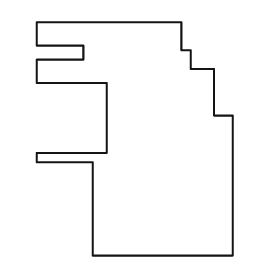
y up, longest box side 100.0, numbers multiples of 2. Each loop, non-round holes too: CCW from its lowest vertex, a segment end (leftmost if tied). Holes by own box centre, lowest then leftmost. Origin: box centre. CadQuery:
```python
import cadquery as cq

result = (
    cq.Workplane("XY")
    .moveTo(-18.0, -50.0)
    .lineTo(42.0, -50.0)
    .lineTo(42.0, 10.0)
    .lineTo(34.0, 10.0)
    .lineTo(34.0, 30.0)
    .lineTo(24.0, 30.0)
    .lineTo(24.0, 38.0)
    .lineTo(20.0, 38.0)
    .lineTo(20.0, 50.0)
    .lineTo(-42.0, 50.0)
    .lineTo(-42.0, 40.0)
    .lineTo(-22.0, 40.0)
    .lineTo(-22.0, 34.0)
    .lineTo(-42.0, 34.0)
    .lineTo(-42.0, 24.0)
    .lineTo(-12.0, 24.0)
    .lineTo(-12.0, -6.0)
    .lineTo(-42.0, -6.0)
    .lineTo(-42.0, -10.0)
    .lineTo(-18.0, -10.0)
    .close()
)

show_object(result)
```